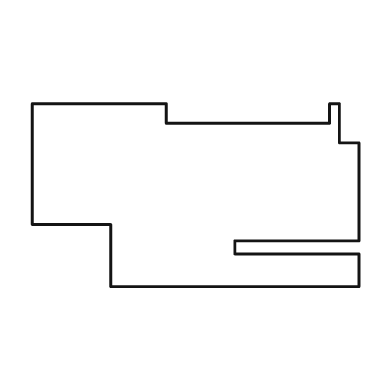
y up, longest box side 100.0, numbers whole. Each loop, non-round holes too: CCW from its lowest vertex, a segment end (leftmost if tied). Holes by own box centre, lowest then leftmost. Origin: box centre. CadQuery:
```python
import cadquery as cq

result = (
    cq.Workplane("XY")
    .moveTo(-26.0, -28.0)
    .lineTo(50.0, -28.0)
    .lineTo(50.0, -18.0)
    .lineTo(12.0, -18.0)
    .lineTo(12.0, -14.0)
    .lineTo(50.0, -14.0)
    .lineTo(50.0, 16.0)
    .lineTo(44.0, 16.0)
    .lineTo(44.0, 28.0)
    .lineTo(41.0, 28.0)
    .lineTo(41.0, 22.0)
    .lineTo(-9.0, 22.0)
    .lineTo(-9.0, 28.0)
    .lineTo(-50.0, 28.0)
    .lineTo(-50.0, -9.0)
    .lineTo(-26.0, -9.0)
    .close()
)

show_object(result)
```